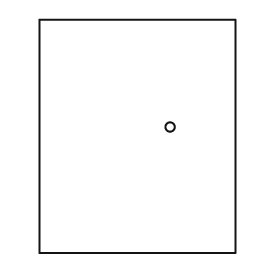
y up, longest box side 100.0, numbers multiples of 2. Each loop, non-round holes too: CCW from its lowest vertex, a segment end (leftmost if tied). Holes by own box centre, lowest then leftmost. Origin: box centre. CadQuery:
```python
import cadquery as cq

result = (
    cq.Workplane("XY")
    .moveTo(-42.0, -50.0)
    .lineTo(42.0, -50.0)
    .lineTo(42.0, 50.0)
    .lineTo(-42.0, 50.0)
    .close()
    .moveTo(14.0, 4.0)
    .circle(2.0)
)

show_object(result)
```